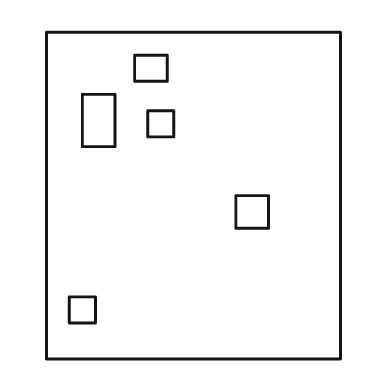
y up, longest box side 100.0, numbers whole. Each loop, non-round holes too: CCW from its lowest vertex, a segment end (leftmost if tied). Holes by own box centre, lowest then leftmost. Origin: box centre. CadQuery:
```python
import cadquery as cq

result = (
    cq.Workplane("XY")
    .moveTo(-45.0, -50.0)
    .lineTo(45.0, -50.0)
    .lineTo(45.0, 50.0)
    .lineTo(-45.0, 50.0)
    .close()
    .moveTo(-38.0, -39.0)
    .lineTo(-30.0, -39.0)
    .lineTo(-30.0, -31.0)
    .lineTo(-38.0, -31.0)
    .close()
    .moveTo(13.0, -10.0)
    .lineTo(23.0, -10.0)
    .lineTo(23.0, 0.0)
    .lineTo(13.0, 0.0)
    .close()
    .moveTo(-14.0, 18.0)
    .lineTo(-6.0, 18.0)
    .lineTo(-6.0, 26.0)
    .lineTo(-14.0, 26.0)
    .close()
    .moveTo(-34.0, 15.0)
    .lineTo(-24.0, 15.0)
    .lineTo(-24.0, 31.0)
    .lineTo(-34.0, 31.0)
    .close()
    .moveTo(-18.0, 35.0)
    .lineTo(-8.0, 35.0)
    .lineTo(-8.0, 43.0)
    .lineTo(-18.0, 43.0)
    .close()
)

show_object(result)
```